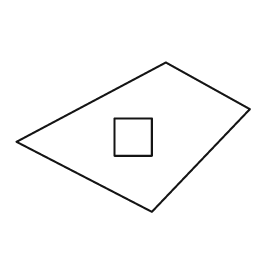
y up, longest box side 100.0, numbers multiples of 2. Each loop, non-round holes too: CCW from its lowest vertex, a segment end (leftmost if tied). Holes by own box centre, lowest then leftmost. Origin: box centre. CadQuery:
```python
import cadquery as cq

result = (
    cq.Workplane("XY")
    .moveTo(8.0, -32.0)
    .lineTo(50.0, 12.0)
    .lineTo(14.0, 32.0)
    .lineTo(-50.0, -2.0)
    .close()
    .moveTo(-8.0, -8.0)
    .lineTo(8.0, -8.0)
    .lineTo(8.0, 8.0)
    .lineTo(-8.0, 8.0)
    .close()
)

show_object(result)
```